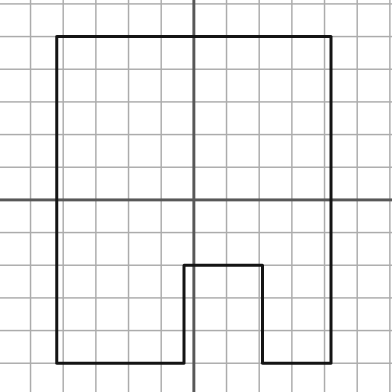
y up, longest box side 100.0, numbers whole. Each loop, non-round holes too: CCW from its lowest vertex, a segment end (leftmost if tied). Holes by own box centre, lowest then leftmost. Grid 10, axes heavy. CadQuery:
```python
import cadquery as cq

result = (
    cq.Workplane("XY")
    .moveTo(-42.0, -50.0)
    .lineTo(-3.0, -50.0)
    .lineTo(-3.0, -20.0)
    .lineTo(21.0, -20.0)
    .lineTo(21.0, -50.0)
    .lineTo(42.0, -50.0)
    .lineTo(42.0, 50.0)
    .lineTo(-42.0, 50.0)
    .close()
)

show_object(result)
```